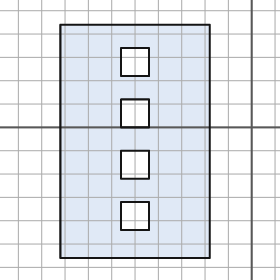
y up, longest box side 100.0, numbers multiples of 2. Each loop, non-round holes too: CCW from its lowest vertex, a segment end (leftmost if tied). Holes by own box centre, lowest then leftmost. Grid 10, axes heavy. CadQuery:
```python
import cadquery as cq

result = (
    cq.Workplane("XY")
    .moveTo(-82.0, -56.0)
    .lineTo(-18.0, -56.0)
    .lineTo(-18.0, 44.0)
    .lineTo(-82.0, 44.0)
    .close()
    .moveTo(-56.0, -44.0)
    .lineTo(-44.0, -44.0)
    .lineTo(-44.0, -32.0)
    .lineTo(-56.0, -32.0)
    .close()
    .moveTo(-56.0, -22.0)
    .lineTo(-44.0, -22.0)
    .lineTo(-44.0, -10.0)
    .lineTo(-56.0, -10.0)
    .close()
    .moveTo(-56.0, 0.0)
    .lineTo(-44.0, 0.0)
    .lineTo(-44.0, 12.0)
    .lineTo(-56.0, 12.0)
    .close()
    .moveTo(-56.0, 22.0)
    .lineTo(-44.0, 22.0)
    .lineTo(-44.0, 34.0)
    .lineTo(-56.0, 34.0)
    .close()
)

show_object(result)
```